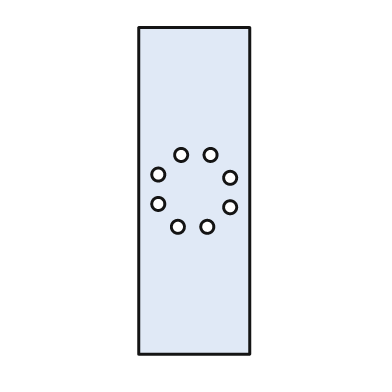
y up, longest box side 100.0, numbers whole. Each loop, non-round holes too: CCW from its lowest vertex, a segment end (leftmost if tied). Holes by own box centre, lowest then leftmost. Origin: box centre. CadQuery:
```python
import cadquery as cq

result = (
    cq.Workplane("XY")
    .moveTo(-17.0, -50.0)
    .lineTo(17.0, -50.0)
    .lineTo(17.0, 50.0)
    .lineTo(-17.0, 50.0)
    .close()
    .moveTo(-5.0, -11.0)
    .circle(2.0)
    .moveTo(4.0, -11.0)
    .circle(2.0)
    .moveTo(11.0, -5.0)
    .circle(2.0)
    .moveTo(-11.0, -4.0)
    .circle(2.0)
    .moveTo(11.0, 4.0)
    .circle(2.0)
    .moveTo(-11.0, 5.0)
    .circle(2.0)
    .moveTo(-4.0, 11.0)
    .circle(2.0)
    .moveTo(5.0, 11.0)
    .circle(2.0)
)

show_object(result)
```